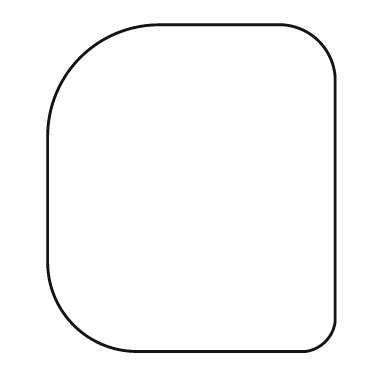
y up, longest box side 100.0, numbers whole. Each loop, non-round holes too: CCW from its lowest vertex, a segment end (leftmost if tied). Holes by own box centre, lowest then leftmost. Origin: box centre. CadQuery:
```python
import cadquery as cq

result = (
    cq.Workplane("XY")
    .moveTo(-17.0, -50.0)
    .lineTo(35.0, -50.0)
    .threePointArc((41.0, -47.0), (44.0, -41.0))
    .lineTo(44.0, 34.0)
    .threePointArc((39.0, 45.0), (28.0, 50.0))
    .lineTo(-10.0, 50.0)
    .threePointArc((-34.0, 40.0), (-44.0, 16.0))
    .lineTo(-44.0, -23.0)
    .threePointArc((-36.0, -42.0), (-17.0, -50.0))
    .close()
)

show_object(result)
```